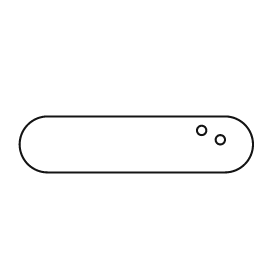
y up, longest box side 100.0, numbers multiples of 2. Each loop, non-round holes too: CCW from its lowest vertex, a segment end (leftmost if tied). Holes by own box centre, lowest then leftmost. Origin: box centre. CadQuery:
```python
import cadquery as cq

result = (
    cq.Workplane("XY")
    .moveTo(-38.0, -12.0)
    .lineTo(38.0, -12.0)
    .threePointArc((50.0, 0.0), (38.0, 12.0))
    .lineTo(-38.0, 12.0)
    .threePointArc((-50.0, 0.0), (-38.0, -12.0))
    .close()
    .moveTo(36.0, 2.0)
    .circle(2.0)
    .moveTo(28.0, 6.0)
    .circle(2.0)
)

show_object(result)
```